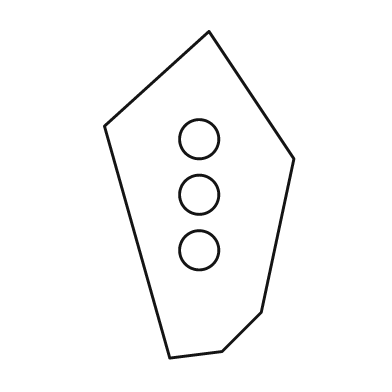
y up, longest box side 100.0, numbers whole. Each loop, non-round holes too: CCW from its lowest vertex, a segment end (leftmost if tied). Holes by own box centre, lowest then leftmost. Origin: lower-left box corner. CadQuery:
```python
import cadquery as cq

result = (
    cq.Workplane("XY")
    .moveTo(20.0, 0.0)
    .lineTo(36.0, 2.0)
    .lineTo(48.0, 14.0)
    .lineTo(58.0, 61.0)
    .lineTo(32.0, 100.0)
    .lineTo(0.0, 71.0)
    .close()
    .moveTo(29.0, 33.0)
    .circle(6.0)
    .moveTo(29.0, 50.0)
    .circle(6.0)
    .moveTo(29.0, 67.0)
    .circle(6.0)
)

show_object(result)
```